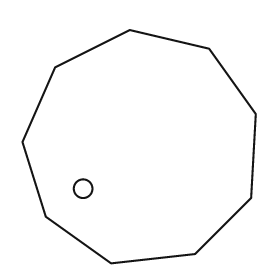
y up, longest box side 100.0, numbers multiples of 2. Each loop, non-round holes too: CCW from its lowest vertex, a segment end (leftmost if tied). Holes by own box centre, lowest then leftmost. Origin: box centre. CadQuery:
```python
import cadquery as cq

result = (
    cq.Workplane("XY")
    .moveTo(-12.0, -50.0)
    .lineTo(24.0, -46.0)
    .lineTo(48.0, -22.0)
    .lineTo(50.0, 14.0)
    .lineTo(30.0, 42.0)
    .lineTo(-4.0, 50.0)
    .lineTo(-36.0, 34.0)
    .lineTo(-50.0, 2.0)
    .lineTo(-40.0, -30.0)
    .close()
    .moveTo(-24.0, -18.0)
    .circle(4.0)
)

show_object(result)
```